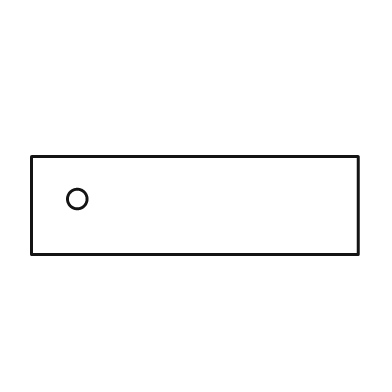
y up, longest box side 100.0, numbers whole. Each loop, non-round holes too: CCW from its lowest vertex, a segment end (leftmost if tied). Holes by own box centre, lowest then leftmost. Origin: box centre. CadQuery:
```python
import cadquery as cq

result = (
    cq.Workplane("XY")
    .moveTo(-50.0, -15.0)
    .lineTo(50.0, -15.0)
    .lineTo(50.0, 15.0)
    .lineTo(-50.0, 15.0)
    .close()
    .moveTo(-36.0, 2.0)
    .circle(3.0)
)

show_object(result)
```